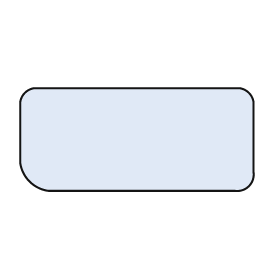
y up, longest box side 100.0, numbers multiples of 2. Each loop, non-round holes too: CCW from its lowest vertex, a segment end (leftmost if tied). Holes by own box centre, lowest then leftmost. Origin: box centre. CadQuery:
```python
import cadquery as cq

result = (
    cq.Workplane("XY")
    .moveTo(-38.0, -22.0)
    .lineTo(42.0, -22.0)
    .threePointArc((48.0, -20.0), (50.0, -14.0))
    .lineTo(50.0, 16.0)
    .threePointArc((48.0, 20.0), (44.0, 22.0))
    .lineTo(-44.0, 22.0)
    .threePointArc((-48.0, 20.0), (-50.0, 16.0))
    .lineTo(-50.0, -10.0)
    .threePointArc((-46.0, -18.0), (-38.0, -22.0))
    .close()
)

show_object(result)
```